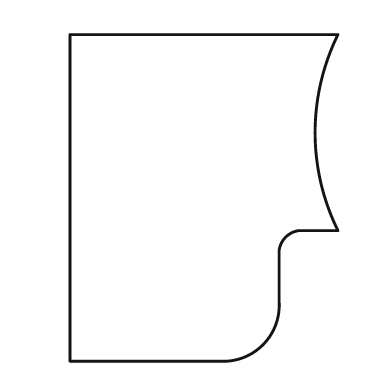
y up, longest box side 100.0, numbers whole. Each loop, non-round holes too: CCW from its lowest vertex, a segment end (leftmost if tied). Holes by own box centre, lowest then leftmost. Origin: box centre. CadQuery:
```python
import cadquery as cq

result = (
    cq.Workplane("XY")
    .moveTo(-41.0, -50.0)
    .lineTo(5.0, -50.0)
    .threePointArc((18.0, -45.0), (23.0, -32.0))
    .lineTo(23.0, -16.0)
    .threePointArc((25.0, -12.0), (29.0, -10.0))
    .lineTo(41.0, -10.0)
    .threePointArc((34.0, 20.0), (41.0, 50.0))
    .lineTo(-41.0, 50.0)
    .close()
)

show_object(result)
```